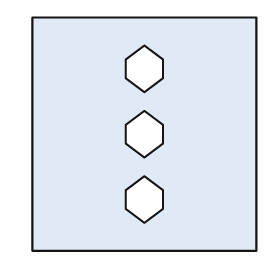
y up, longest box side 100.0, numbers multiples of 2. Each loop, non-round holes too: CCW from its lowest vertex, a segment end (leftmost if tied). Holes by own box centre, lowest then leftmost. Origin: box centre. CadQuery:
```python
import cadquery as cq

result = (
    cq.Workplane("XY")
    .moveTo(-48.0, -50.0)
    .lineTo(48.0, -50.0)
    .lineTo(48.0, 50.0)
    .lineTo(-48.0, 50.0)
    .close()
    .moveTo(0.0, -38.0)
    .lineTo(8.0, -32.0)
    .lineTo(8.0, -24.0)
    .lineTo(0.0, -18.0)
    .lineTo(-8.0, -24.0)
    .lineTo(-8.0, -32.0)
    .close()
    .moveTo(0.0, -10.0)
    .lineTo(8.0, -4.0)
    .lineTo(8.0, 4.0)
    .lineTo(0.0, 10.0)
    .lineTo(-8.0, 4.0)
    .lineTo(-8.0, -4.0)
    .close()
    .moveTo(0.0, 18.0)
    .lineTo(8.0, 24.0)
    .lineTo(8.0, 32.0)
    .lineTo(0.0, 38.0)
    .lineTo(-8.0, 32.0)
    .lineTo(-8.0, 24.0)
    .close()
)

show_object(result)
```